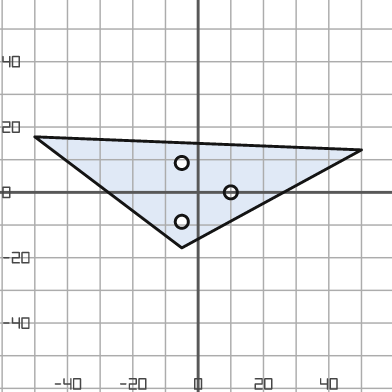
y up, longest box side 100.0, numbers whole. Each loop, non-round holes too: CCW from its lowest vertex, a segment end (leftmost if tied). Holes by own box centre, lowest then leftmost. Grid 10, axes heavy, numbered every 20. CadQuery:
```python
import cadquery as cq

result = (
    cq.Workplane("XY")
    .moveTo(-5.0, -17.0)
    .lineTo(50.0, 13.0)
    .lineTo(-50.0, 17.0)
    .close()
    .moveTo(-5.0, -9.0)
    .circle(2.0)
    .moveTo(10.0, 0.0)
    .circle(2.0)
    .moveTo(-5.0, 9.0)
    .circle(2.0)
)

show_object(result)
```